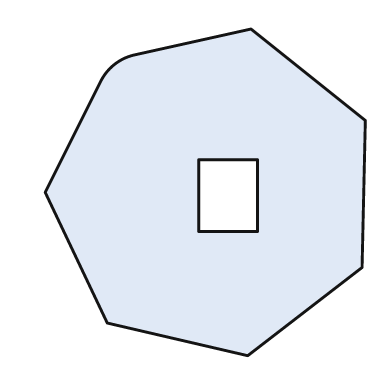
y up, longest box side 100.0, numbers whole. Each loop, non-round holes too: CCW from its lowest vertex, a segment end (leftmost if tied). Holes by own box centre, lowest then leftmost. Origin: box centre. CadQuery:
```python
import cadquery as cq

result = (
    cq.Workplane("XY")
    .moveTo(13.0, -50.0)
    .lineTo(48.0, -23.0)
    .lineTo(49.0, 22.0)
    .lineTo(14.0, 50.0)
    .lineTo(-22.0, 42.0)
    .threePointArc((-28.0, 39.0), (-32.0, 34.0))
    .lineTo(-49.0, 0.0)
    .lineTo(-30.0, -40.0)
    .close()
    .moveTo(-2.0, -12.0)
    .lineTo(16.0, -12.0)
    .lineTo(16.0, 10.0)
    .lineTo(-2.0, 10.0)
    .close()
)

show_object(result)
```